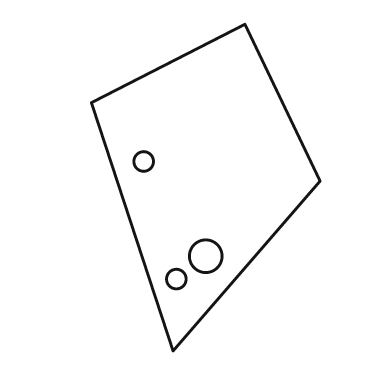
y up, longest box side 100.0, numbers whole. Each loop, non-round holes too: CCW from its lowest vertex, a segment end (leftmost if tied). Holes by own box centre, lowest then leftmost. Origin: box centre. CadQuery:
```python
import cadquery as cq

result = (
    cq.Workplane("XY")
    .moveTo(-10.0, -50.0)
    .lineTo(35.0, 2.0)
    .lineTo(12.0, 50.0)
    .lineTo(-35.0, 26.0)
    .close()
    .moveTo(-9.0, -28.0)
    .circle(3.0)
    .moveTo(0.0, -21.0)
    .circle(5.0)
    .moveTo(-19.0, 8.0)
    .circle(3.0)
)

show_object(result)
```